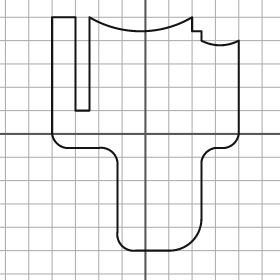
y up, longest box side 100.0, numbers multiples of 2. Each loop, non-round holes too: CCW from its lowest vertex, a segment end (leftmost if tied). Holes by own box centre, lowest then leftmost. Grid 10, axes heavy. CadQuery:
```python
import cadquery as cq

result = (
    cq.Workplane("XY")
    .moveTo(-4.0, -50.0)
    .lineTo(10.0, -50.0)
    .threePointArc((20.0, -46.0), (24.0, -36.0))
    .lineTo(24.0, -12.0)
    .threePointArc((26.0, -8.0), (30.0, -6.0))
    .lineTo(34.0, -6.0)
    .threePointArc((38.0, -4.0), (40.0, 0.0))
    .lineTo(40.0, 40.0)
    .threePointArc((32.0, 38.0), (24.0, 40.0))
    .lineTo(24.0, 44.0)
    .lineTo(20.0, 44.0)
    .lineTo(20.0, 50.0)
    .threePointArc((-2.0, 44.0), (-24.0, 50.0))
    .lineTo(-24.0, 10.0)
    .lineTo(-30.0, 10.0)
    .lineTo(-30.0, 50.0)
    .lineTo(-40.0, 50.0)
    .lineTo(-40.0, 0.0)
    .threePointArc((-38.0, -4.0), (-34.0, -6.0))
    .lineTo(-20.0, -6.0)
    .threePointArc((-14.0, -8.0), (-12.0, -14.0))
    .lineTo(-12.0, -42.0)
    .threePointArc((-10.0, -48.0), (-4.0, -50.0))
    .close()
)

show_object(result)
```